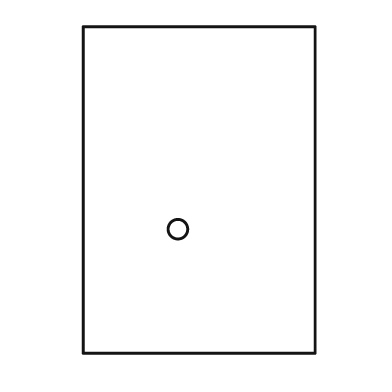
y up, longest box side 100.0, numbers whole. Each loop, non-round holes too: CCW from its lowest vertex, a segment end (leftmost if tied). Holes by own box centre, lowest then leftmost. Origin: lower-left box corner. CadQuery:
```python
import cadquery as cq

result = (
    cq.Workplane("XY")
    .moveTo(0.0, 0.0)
    .lineTo(71.0, 0.0)
    .lineTo(71.0, 100.0)
    .lineTo(0.0, 100.0)
    .close()
    .moveTo(29.0, 38.0)
    .circle(3.0)
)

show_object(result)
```